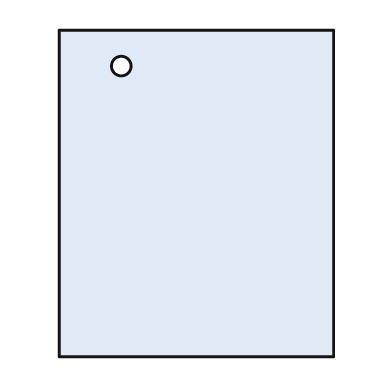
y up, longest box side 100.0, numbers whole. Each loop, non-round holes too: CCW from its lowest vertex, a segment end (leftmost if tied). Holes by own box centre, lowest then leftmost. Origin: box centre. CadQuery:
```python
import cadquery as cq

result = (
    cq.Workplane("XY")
    .moveTo(-42.0, -50.0)
    .lineTo(42.0, -50.0)
    .lineTo(42.0, 50.0)
    .lineTo(-42.0, 50.0)
    .close()
    .moveTo(-23.0, 39.0)
    .circle(3.0)
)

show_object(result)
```